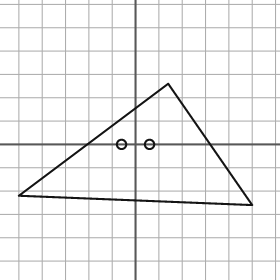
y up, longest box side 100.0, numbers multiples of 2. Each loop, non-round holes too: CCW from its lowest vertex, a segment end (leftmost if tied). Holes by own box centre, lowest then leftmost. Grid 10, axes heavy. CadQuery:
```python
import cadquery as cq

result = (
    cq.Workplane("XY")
    .moveTo(50.0, -26.0)
    .lineTo(14.0, 26.0)
    .lineTo(-50.0, -22.0)
    .close()
    .moveTo(-6.0, 0.0)
    .circle(2.0)
    .moveTo(6.0, 0.0)
    .circle(2.0)
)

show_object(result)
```